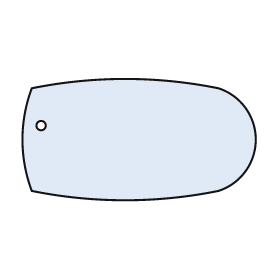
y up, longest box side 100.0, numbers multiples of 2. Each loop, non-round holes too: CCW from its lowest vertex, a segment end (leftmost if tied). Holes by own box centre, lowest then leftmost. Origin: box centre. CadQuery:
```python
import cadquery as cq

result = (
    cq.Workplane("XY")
    .moveTo(-46.0, -22.0)
    .threePointArc((-6.0, -26.0), (34.0, -22.0))
    .threePointArc((50.0, 0.0), (34.0, 22.0))
    .threePointArc((-6.0, 26.0), (-46.0, 22.0))
    .threePointArc((-50.0, 0.0), (-46.0, -22.0))
    .close()
    .moveTo(-42.0, 6.0)
    .circle(2.0)
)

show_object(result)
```